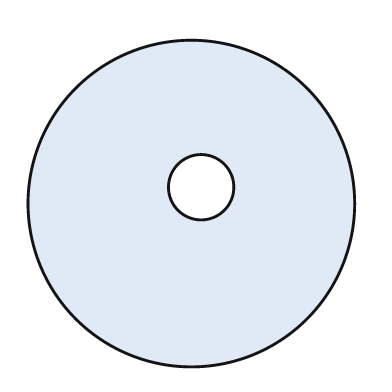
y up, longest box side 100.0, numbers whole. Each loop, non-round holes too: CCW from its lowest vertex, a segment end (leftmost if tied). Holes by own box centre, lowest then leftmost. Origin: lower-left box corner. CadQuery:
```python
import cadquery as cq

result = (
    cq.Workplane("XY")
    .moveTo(50.0, 50.0)
    .circle(50.0)
    .moveTo(53.0, 55.0)
    .circle(10.0)
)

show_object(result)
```